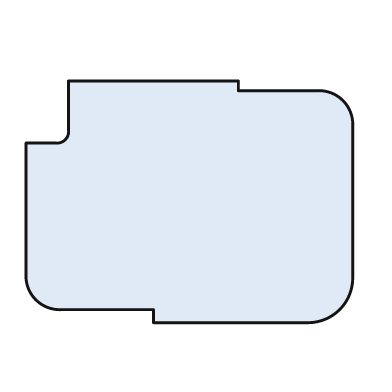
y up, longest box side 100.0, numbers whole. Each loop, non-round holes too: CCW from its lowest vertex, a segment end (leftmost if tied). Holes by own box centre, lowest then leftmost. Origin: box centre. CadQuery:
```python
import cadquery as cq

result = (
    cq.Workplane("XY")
    .moveTo(-11.0, -37.0)
    .lineTo(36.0, -37.0)
    .threePointArc((46.0, -33.0), (50.0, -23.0))
    .lineTo(50.0, 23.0)
    .threePointArc((47.0, 31.0), (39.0, 34.0))
    .lineTo(15.0, 34.0)
    .lineTo(15.0, 37.0)
    .lineTo(-37.0, 37.0)
    .lineTo(-37.0, 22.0)
    .threePointArc((-38.0, 19.0), (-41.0, 18.0))
    .lineTo(-50.0, 18.0)
    .lineTo(-50.0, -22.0)
    .threePointArc((-47.0, -30.0), (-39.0, -33.0))
    .lineTo(-11.0, -33.0)
    .close()
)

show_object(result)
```